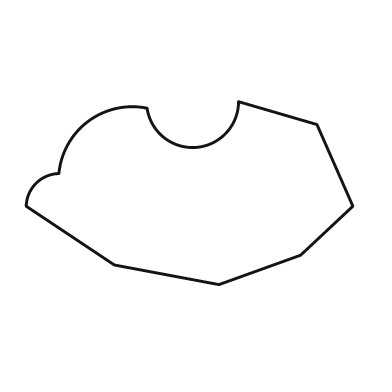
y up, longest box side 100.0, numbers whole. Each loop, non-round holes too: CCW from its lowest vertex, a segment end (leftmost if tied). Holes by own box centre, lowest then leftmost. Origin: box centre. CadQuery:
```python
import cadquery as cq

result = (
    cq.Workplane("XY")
    .moveTo(9.0, -28.0)
    .lineTo(34.0, -19.0)
    .lineTo(50.0, -4.0)
    .lineTo(39.0, 21.0)
    .lineTo(15.0, 28.0)
    .threePointArc((2.0, 14.0), (-13.0, 26.0))
    .threePointArc((-31.0, 22.0), (-40.0, 6.0))
    .threePointArc((-47.0, 3.0), (-50.0, -4.0))
    .lineTo(-23.0, -22.0)
    .close()
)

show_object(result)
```